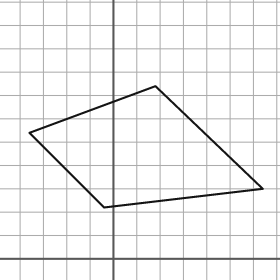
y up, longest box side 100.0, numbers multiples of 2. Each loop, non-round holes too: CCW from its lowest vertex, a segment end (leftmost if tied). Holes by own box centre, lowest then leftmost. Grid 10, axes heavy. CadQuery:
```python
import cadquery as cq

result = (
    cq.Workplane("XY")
    .moveTo(-4.0, 22.0)
    .lineTo(64.0, 30.0)
    .lineTo(18.0, 74.0)
    .lineTo(-36.0, 54.0)
    .close()
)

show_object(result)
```